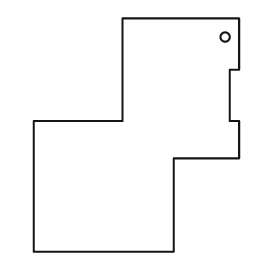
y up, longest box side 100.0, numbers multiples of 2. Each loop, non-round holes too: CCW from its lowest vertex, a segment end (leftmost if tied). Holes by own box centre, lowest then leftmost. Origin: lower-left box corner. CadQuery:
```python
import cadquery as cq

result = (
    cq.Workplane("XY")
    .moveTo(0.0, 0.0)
    .lineTo(60.0, 0.0)
    .lineTo(60.0, 40.0)
    .lineTo(88.0, 40.0)
    .lineTo(88.0, 56.0)
    .lineTo(84.0, 56.0)
    .lineTo(84.0, 78.0)
    .lineTo(88.0, 78.0)
    .lineTo(88.0, 100.0)
    .lineTo(38.0, 100.0)
    .lineTo(38.0, 56.0)
    .lineTo(0.0, 56.0)
    .close()
    .moveTo(82.0, 92.0)
    .circle(2.0)
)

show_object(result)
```